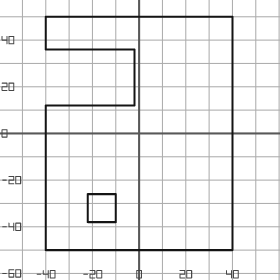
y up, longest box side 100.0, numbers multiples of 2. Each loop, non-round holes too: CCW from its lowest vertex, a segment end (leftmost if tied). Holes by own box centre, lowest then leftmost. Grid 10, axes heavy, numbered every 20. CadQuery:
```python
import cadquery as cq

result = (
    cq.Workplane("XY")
    .moveTo(-40.0, -50.0)
    .lineTo(40.0, -50.0)
    .lineTo(40.0, 50.0)
    .lineTo(-40.0, 50.0)
    .lineTo(-40.0, 36.0)
    .lineTo(-2.0, 36.0)
    .lineTo(-2.0, 12.0)
    .lineTo(-40.0, 12.0)
    .close()
    .moveTo(-22.0, -38.0)
    .lineTo(-10.0, -38.0)
    .lineTo(-10.0, -26.0)
    .lineTo(-22.0, -26.0)
    .close()
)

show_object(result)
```